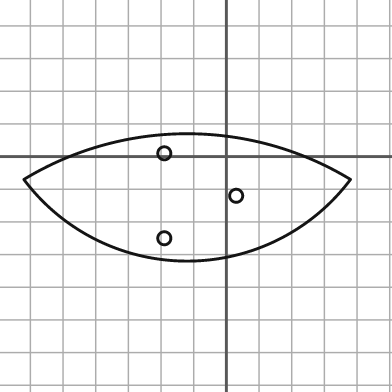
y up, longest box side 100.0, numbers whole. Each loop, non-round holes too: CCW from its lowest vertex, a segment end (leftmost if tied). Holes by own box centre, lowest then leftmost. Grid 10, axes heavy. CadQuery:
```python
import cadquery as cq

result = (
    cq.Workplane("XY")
    .moveTo(-62.0, -7.0)
    .threePointArc((-12.0, -32.0), (38.0, -7.0))
    .threePointArc((-12.0, 7.0), (-62.0, -7.0))
    .close()
    .moveTo(-19.0, -25.0)
    .circle(2.0)
    .moveTo(3.0, -12.0)
    .circle(2.0)
    .moveTo(-19.0, 1.0)
    .circle(2.0)
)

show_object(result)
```